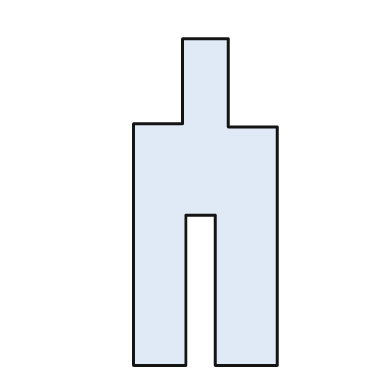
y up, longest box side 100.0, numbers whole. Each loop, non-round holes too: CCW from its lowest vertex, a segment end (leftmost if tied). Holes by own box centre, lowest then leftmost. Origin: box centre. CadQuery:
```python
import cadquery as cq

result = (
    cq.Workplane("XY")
    .moveTo(-22.0, -50.0)
    .lineTo(-6.0, -50.0)
    .lineTo(-6.0, -4.0)
    .lineTo(3.0, -4.0)
    .lineTo(3.0, -50.0)
    .lineTo(22.0, -50.0)
    .lineTo(22.0, 23.0)
    .lineTo(7.0, 23.0)
    .lineTo(7.0, 50.0)
    .lineTo(-7.0, 50.0)
    .lineTo(-7.0, 24.0)
    .lineTo(-22.0, 24.0)
    .close()
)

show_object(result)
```